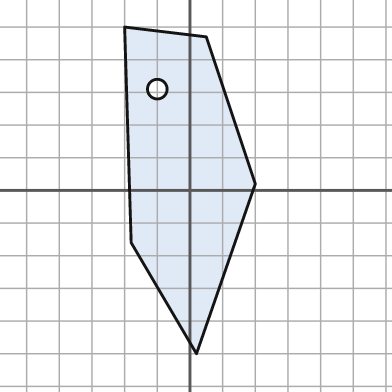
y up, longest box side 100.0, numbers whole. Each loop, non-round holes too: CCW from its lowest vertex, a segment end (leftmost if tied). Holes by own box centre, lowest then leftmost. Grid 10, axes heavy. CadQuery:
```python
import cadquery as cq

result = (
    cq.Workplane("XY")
    .moveTo(2.0, -50.0)
    .lineTo(20.0, 2.0)
    .lineTo(5.0, 47.0)
    .lineTo(-20.0, 50.0)
    .lineTo(-18.0, -16.0)
    .close()
    .moveTo(-10.0, 31.0)
    .circle(3.0)
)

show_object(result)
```